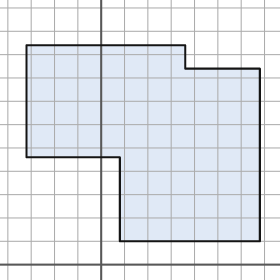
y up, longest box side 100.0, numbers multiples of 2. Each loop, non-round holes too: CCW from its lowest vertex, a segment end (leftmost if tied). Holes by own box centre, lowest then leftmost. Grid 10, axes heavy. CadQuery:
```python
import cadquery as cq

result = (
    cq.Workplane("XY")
    .moveTo(8.0, 10.0)
    .lineTo(68.0, 10.0)
    .lineTo(68.0, 84.0)
    .lineTo(36.0, 84.0)
    .lineTo(36.0, 94.0)
    .lineTo(-32.0, 94.0)
    .lineTo(-32.0, 46.0)
    .lineTo(8.0, 46.0)
    .close()
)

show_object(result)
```